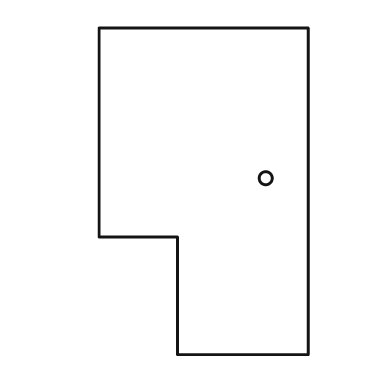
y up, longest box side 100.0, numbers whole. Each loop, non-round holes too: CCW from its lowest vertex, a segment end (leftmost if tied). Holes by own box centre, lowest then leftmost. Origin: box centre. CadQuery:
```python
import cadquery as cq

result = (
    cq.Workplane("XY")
    .moveTo(-8.0, -50.0)
    .lineTo(32.0, -50.0)
    .lineTo(32.0, 50.0)
    .lineTo(-32.0, 50.0)
    .lineTo(-32.0, -14.0)
    .lineTo(-8.0, -14.0)
    .close()
    .moveTo(19.0, 4.0)
    .circle(2.0)
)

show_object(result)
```